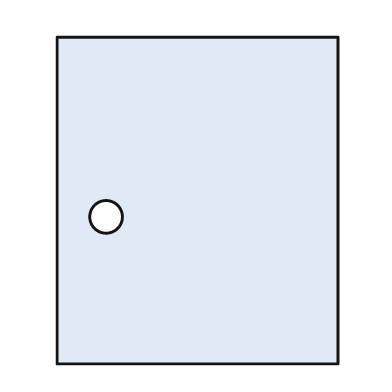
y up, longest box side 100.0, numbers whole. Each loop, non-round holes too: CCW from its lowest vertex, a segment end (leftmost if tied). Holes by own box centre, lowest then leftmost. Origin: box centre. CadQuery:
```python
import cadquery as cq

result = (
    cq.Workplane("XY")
    .moveTo(-43.0, -50.0)
    .lineTo(43.0, -50.0)
    .lineTo(43.0, 50.0)
    .lineTo(-43.0, 50.0)
    .close()
    .moveTo(-28.0, -5.0)
    .circle(5.0)
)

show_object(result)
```